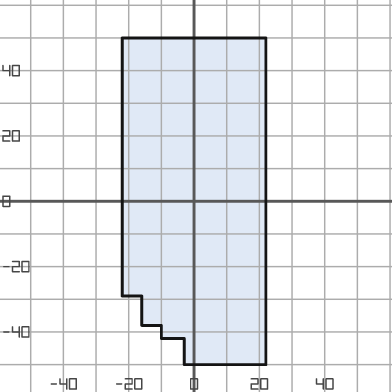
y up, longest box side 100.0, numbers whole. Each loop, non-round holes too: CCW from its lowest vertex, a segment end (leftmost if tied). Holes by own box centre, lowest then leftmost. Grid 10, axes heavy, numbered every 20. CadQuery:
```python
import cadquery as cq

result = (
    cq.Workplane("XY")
    .moveTo(-3.0, -50.0)
    .lineTo(22.0, -50.0)
    .lineTo(22.0, 50.0)
    .lineTo(-22.0, 50.0)
    .lineTo(-22.0, -29.0)
    .lineTo(-16.0, -29.0)
    .lineTo(-16.0, -38.0)
    .lineTo(-10.0, -38.0)
    .lineTo(-10.0, -42.0)
    .lineTo(-3.0, -42.0)
    .close()
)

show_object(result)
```